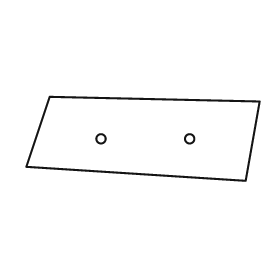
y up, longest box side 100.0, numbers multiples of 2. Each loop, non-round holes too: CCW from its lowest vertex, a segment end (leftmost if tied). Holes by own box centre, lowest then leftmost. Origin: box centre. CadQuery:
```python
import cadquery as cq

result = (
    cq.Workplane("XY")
    .moveTo(44.0, -18.0)
    .lineTo(50.0, 16.0)
    .lineTo(-40.0, 18.0)
    .lineTo(-50.0, -12.0)
    .close()
    .moveTo(-18.0, 0.0)
    .circle(2.0)
    .moveTo(20.0, 0.0)
    .circle(2.0)
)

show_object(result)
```